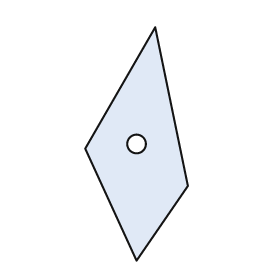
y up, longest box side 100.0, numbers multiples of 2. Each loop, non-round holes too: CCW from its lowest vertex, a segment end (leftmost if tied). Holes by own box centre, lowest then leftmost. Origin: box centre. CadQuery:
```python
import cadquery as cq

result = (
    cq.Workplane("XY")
    .moveTo(0.0, -50.0)
    .lineTo(22.0, -18.0)
    .lineTo(8.0, 50.0)
    .lineTo(-22.0, -2.0)
    .close()
    .moveTo(0.0, 0.0)
    .circle(4.0)
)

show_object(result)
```